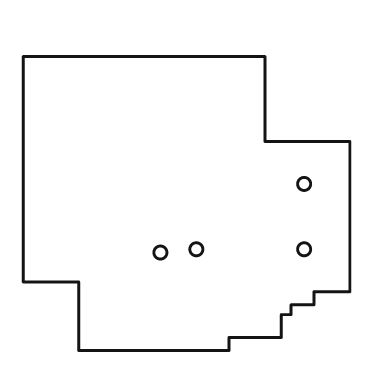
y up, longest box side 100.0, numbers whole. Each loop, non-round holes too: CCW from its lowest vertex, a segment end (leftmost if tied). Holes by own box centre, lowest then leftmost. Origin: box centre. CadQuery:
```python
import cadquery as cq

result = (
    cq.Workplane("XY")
    .moveTo(-33.0, -45.0)
    .lineTo(13.0, -45.0)
    .lineTo(13.0, -41.0)
    .lineTo(29.0, -41.0)
    .lineTo(29.0, -34.0)
    .lineTo(32.0, -34.0)
    .lineTo(32.0, -31.0)
    .lineTo(39.0, -31.0)
    .lineTo(39.0, -27.0)
    .lineTo(50.0, -27.0)
    .lineTo(50.0, 19.0)
    .lineTo(24.0, 19.0)
    .lineTo(24.0, 45.0)
    .lineTo(-50.0, 45.0)
    .lineTo(-50.0, -24.0)
    .lineTo(-33.0, -24.0)
    .close()
    .moveTo(-8.0, -15.0)
    .circle(2.0)
    .moveTo(3.0, -14.0)
    .circle(2.0)
    .moveTo(36.0, -14.0)
    .circle(2.0)
    .moveTo(36.0, 6.0)
    .circle(2.0)
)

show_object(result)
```